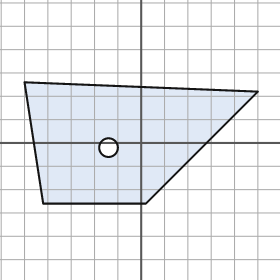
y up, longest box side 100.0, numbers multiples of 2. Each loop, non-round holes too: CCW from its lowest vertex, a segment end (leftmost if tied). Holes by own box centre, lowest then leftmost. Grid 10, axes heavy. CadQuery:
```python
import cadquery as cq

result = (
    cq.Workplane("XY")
    .moveTo(-42.0, -26.0)
    .lineTo(2.0, -26.0)
    .lineTo(50.0, 22.0)
    .lineTo(-50.0, 26.0)
    .close()
    .moveTo(-14.0, -2.0)
    .circle(4.0)
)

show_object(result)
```